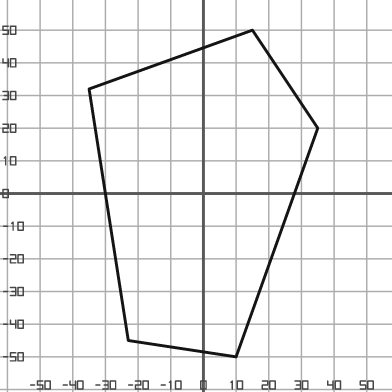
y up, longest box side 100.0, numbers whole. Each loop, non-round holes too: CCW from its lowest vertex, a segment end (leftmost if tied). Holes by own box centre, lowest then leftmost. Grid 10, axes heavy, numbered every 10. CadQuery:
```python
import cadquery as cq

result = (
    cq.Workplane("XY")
    .moveTo(10.0, -50.0)
    .lineTo(35.0, 20.0)
    .lineTo(15.0, 50.0)
    .lineTo(-35.0, 32.0)
    .lineTo(-23.0, -45.0)
    .close()
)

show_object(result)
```